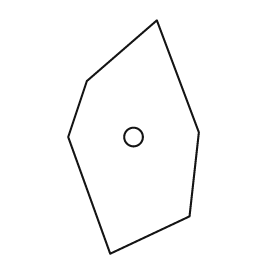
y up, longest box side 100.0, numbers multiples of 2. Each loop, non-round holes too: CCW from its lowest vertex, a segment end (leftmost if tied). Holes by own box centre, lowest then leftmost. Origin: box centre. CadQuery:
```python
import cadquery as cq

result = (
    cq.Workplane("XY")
    .moveTo(-10.0, -50.0)
    .lineTo(24.0, -34.0)
    .lineTo(28.0, 2.0)
    .lineTo(10.0, 50.0)
    .lineTo(-20.0, 24.0)
    .lineTo(-28.0, 0.0)
    .close()
    .moveTo(0.0, 0.0)
    .circle(4.0)
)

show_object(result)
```